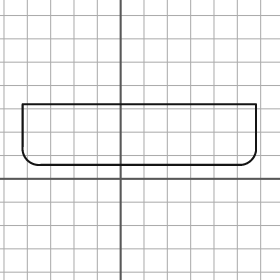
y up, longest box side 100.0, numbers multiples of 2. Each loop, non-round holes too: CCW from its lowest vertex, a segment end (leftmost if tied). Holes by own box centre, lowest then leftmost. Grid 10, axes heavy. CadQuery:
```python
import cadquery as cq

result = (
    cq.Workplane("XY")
    .moveTo(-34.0, 6.0)
    .lineTo(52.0, 6.0)
    .threePointArc((56.0, 8.0), (58.0, 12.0))
    .lineTo(58.0, 32.0)
    .lineTo(-42.0, 32.0)
    .lineTo(-42.0, 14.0)
    .threePointArc((-40.0, 8.0), (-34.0, 6.0))
    .close()
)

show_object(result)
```